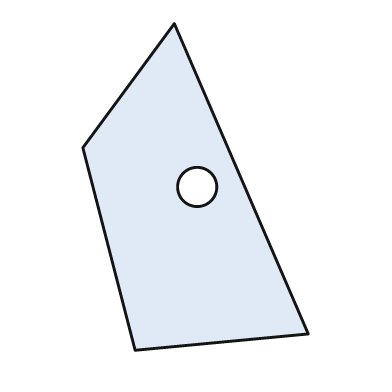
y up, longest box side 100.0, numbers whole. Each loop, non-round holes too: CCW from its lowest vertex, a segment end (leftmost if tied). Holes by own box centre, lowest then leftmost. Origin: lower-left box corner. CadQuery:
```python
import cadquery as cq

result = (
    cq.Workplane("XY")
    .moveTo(16.0, 0.0)
    .lineTo(69.0, 5.0)
    .lineTo(28.0, 100.0)
    .lineTo(0.0, 62.0)
    .close()
    .moveTo(35.0, 50.0)
    .circle(6.0)
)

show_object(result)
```